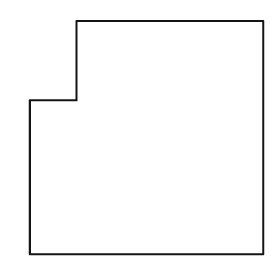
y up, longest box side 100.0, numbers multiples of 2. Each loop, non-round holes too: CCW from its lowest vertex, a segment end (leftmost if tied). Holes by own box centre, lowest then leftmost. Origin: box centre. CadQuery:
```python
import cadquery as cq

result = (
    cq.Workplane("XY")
    .moveTo(-50.0, -50.0)
    .lineTo(50.0, -50.0)
    .lineTo(50.0, 50.0)
    .lineTo(-30.0, 50.0)
    .lineTo(-30.0, 16.0)
    .lineTo(-50.0, 16.0)
    .close()
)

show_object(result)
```